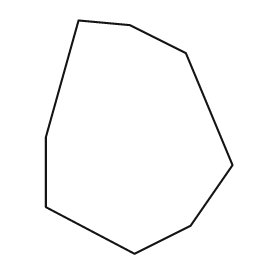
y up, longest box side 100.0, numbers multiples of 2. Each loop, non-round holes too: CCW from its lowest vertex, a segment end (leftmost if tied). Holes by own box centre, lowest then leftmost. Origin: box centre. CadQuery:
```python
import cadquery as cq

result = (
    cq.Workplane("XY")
    .moveTo(-2.0, -50.0)
    .lineTo(22.0, -38.0)
    .lineTo(40.0, -12.0)
    .lineTo(20.0, 36.0)
    .lineTo(-4.0, 48.0)
    .lineTo(-26.0, 50.0)
    .lineTo(-40.0, 0.0)
    .lineTo(-40.0, -30.0)
    .close()
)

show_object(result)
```